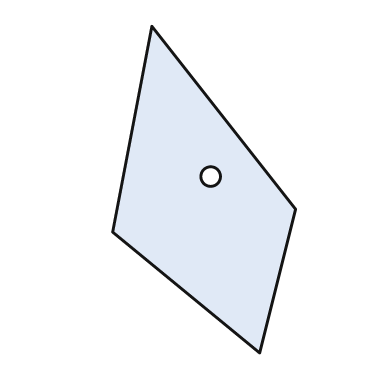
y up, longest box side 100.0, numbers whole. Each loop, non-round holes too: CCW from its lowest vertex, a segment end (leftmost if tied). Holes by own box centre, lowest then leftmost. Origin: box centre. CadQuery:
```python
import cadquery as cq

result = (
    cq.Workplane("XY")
    .moveTo(17.0, -50.0)
    .lineTo(28.0, -6.0)
    .lineTo(-16.0, 50.0)
    .lineTo(-28.0, -13.0)
    .close()
    .moveTo(2.0, 4.0)
    .circle(3.0)
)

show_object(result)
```